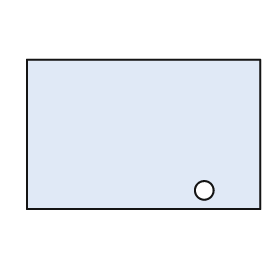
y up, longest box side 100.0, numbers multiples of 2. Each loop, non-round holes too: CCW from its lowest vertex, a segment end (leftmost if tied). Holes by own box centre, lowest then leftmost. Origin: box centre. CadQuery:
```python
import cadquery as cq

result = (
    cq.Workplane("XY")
    .moveTo(-50.0, -32.0)
    .lineTo(50.0, -32.0)
    .lineTo(50.0, 32.0)
    .lineTo(-50.0, 32.0)
    .close()
    .moveTo(26.0, -24.0)
    .circle(4.0)
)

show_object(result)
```